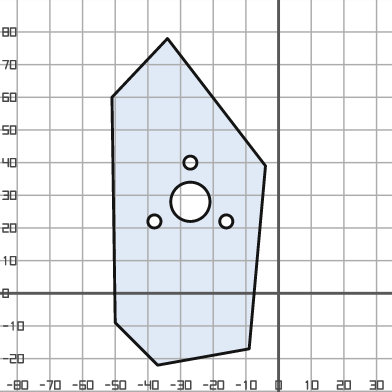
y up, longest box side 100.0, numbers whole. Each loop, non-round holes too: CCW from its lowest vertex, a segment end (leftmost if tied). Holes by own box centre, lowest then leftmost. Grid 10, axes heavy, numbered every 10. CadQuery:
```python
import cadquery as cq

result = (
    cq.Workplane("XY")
    .moveTo(-37.0, -22.0)
    .lineTo(-9.0, -17.0)
    .lineTo(-4.0, 39.0)
    .lineTo(-34.0, 78.0)
    .lineTo(-51.0, 60.0)
    .lineTo(-50.0, -9.0)
    .close()
    .moveTo(-38.0, 22.0)
    .circle(2.0)
    .moveTo(-16.0, 22.0)
    .circle(2.0)
    .moveTo(-27.0, 28.0)
    .circle(6.0)
    .moveTo(-27.0, 40.0)
    .circle(2.0)
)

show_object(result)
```